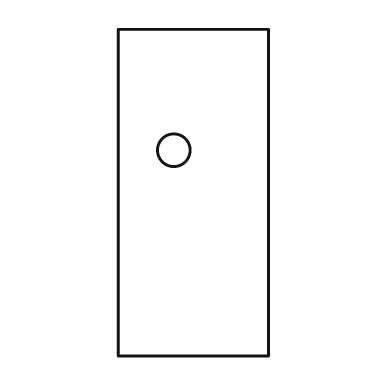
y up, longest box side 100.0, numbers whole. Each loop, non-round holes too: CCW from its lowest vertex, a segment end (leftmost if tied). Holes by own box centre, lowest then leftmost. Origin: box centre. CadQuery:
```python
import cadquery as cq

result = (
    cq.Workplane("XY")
    .moveTo(-23.0, -50.0)
    .lineTo(23.0, -50.0)
    .lineTo(23.0, 50.0)
    .lineTo(-23.0, 50.0)
    .close()
    .moveTo(-6.0, 13.0)
    .circle(5.0)
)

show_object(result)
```